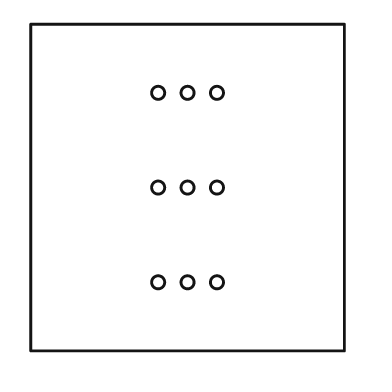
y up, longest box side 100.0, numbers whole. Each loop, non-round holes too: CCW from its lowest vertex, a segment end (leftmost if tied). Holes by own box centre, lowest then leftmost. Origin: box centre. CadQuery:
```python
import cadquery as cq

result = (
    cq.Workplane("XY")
    .moveTo(-48.0, -50.0)
    .lineTo(48.0, -50.0)
    .lineTo(48.0, 50.0)
    .lineTo(-48.0, 50.0)
    .close()
    .moveTo(-9.0, -29.0)
    .circle(2.0)
    .moveTo(0.0, -29.0)
    .circle(2.0)
    .moveTo(9.0, -29.0)
    .circle(2.0)
    .moveTo(-9.0, 0.0)
    .circle(2.0)
    .moveTo(0.0, 0.0)
    .circle(2.0)
    .moveTo(9.0, 0.0)
    .circle(2.0)
    .moveTo(-9.0, 29.0)
    .circle(2.0)
    .moveTo(0.0, 29.0)
    .circle(2.0)
    .moveTo(9.0, 29.0)
    .circle(2.0)
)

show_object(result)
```